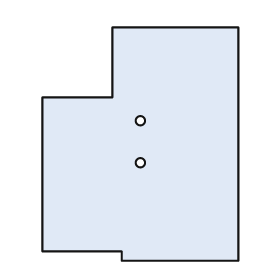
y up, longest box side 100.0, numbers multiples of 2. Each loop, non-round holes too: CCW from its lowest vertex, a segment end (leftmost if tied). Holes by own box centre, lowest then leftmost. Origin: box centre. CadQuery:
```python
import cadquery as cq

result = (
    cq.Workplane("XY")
    .moveTo(-8.0, -50.0)
    .lineTo(42.0, -50.0)
    .lineTo(42.0, 50.0)
    .lineTo(-12.0, 50.0)
    .lineTo(-12.0, 20.0)
    .lineTo(-42.0, 20.0)
    .lineTo(-42.0, -46.0)
    .lineTo(-8.0, -46.0)
    .close()
    .moveTo(0.0, -8.0)
    .circle(2.0)
    .moveTo(0.0, 10.0)
    .circle(2.0)
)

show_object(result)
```